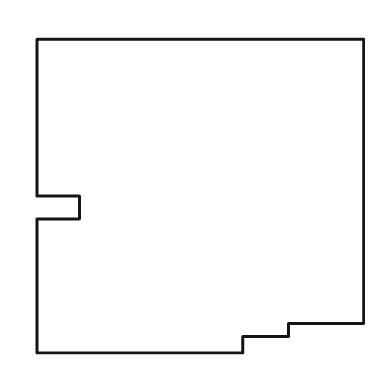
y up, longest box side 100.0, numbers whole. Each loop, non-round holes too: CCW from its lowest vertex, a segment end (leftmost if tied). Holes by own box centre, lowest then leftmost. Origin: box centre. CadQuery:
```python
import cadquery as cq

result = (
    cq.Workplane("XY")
    .moveTo(-50.0, -48.0)
    .lineTo(13.0, -48.0)
    .lineTo(13.0, -43.0)
    .lineTo(27.0, -43.0)
    .lineTo(27.0, -39.0)
    .lineTo(50.0, -39.0)
    .lineTo(50.0, 48.0)
    .lineTo(-50.0, 48.0)
    .lineTo(-50.0, 0.0)
    .lineTo(-37.0, 0.0)
    .lineTo(-37.0, -7.0)
    .lineTo(-50.0, -7.0)
    .close()
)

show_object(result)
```